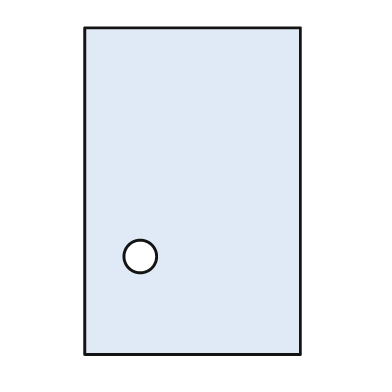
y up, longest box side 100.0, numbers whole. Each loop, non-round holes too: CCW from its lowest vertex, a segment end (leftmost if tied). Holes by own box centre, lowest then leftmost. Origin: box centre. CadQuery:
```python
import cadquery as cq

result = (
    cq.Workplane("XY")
    .moveTo(-33.0, -50.0)
    .lineTo(33.0, -50.0)
    .lineTo(33.0, 50.0)
    .lineTo(-33.0, 50.0)
    .close()
    .moveTo(-16.0, -20.0)
    .circle(5.0)
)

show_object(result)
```